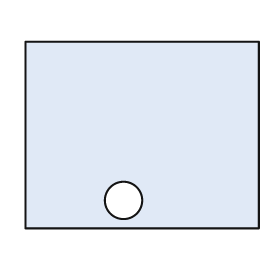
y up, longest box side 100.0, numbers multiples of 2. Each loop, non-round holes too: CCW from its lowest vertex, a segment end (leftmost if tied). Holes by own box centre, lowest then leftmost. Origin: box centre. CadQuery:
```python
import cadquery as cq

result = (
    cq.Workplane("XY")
    .moveTo(-50.0, -40.0)
    .lineTo(50.0, -40.0)
    .lineTo(50.0, 40.0)
    .lineTo(-50.0, 40.0)
    .close()
    .moveTo(-8.0, -28.0)
    .circle(8.0)
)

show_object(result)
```